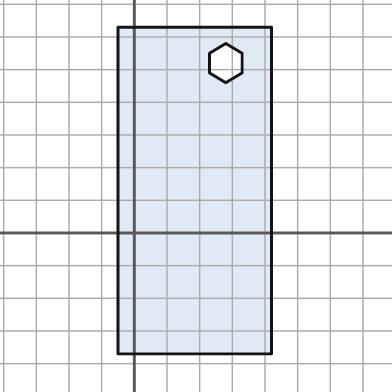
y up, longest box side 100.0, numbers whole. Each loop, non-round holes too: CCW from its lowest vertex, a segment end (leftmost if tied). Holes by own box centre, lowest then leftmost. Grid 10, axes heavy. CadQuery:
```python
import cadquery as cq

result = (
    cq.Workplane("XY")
    .moveTo(-5.0, -37.0)
    .lineTo(42.0, -37.0)
    .lineTo(42.0, 63.0)
    .lineTo(-5.0, 63.0)
    .close()
    .moveTo(28.0, 46.0)
    .lineTo(33.0, 49.0)
    .lineTo(33.0, 55.0)
    .lineTo(28.0, 58.0)
    .lineTo(23.0, 55.0)
    .lineTo(23.0, 49.0)
    .close()
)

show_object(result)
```